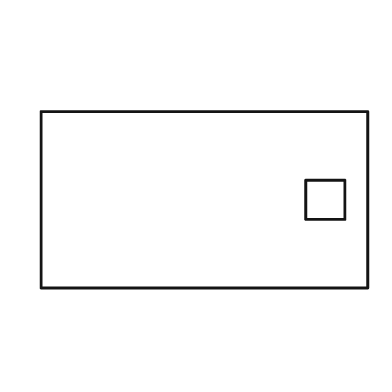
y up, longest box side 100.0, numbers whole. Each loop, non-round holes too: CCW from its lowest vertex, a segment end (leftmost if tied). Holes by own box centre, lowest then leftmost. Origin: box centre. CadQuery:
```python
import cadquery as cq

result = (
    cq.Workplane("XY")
    .moveTo(-50.0, -27.0)
    .lineTo(50.0, -27.0)
    .lineTo(50.0, 27.0)
    .lineTo(-50.0, 27.0)
    .close()
    .moveTo(31.0, -6.0)
    .lineTo(43.0, -6.0)
    .lineTo(43.0, 6.0)
    .lineTo(31.0, 6.0)
    .close()
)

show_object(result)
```